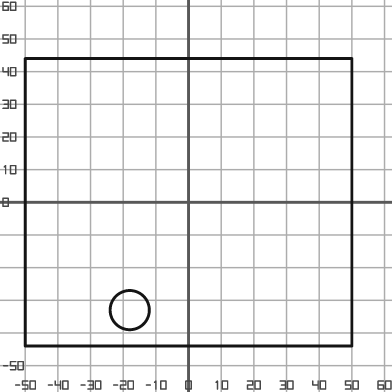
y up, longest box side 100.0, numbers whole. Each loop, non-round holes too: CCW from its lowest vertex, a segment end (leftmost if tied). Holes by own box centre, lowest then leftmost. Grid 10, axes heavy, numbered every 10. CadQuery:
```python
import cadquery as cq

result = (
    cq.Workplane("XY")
    .moveTo(-50.0, -44.0)
    .lineTo(50.0, -44.0)
    .lineTo(50.0, 44.0)
    .lineTo(-50.0, 44.0)
    .close()
    .moveTo(-18.0, -33.0)
    .circle(6.0)
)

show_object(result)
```